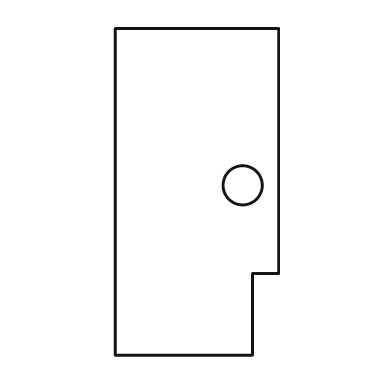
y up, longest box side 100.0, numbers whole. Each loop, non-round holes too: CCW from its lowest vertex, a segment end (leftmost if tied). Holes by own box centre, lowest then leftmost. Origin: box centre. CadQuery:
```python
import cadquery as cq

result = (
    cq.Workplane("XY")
    .moveTo(-25.0, -50.0)
    .lineTo(17.0, -50.0)
    .lineTo(17.0, -25.0)
    .lineTo(25.0, -25.0)
    .lineTo(25.0, 50.0)
    .lineTo(-25.0, 50.0)
    .close()
    .moveTo(14.0, 2.0)
    .circle(6.0)
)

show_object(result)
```